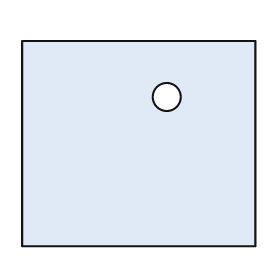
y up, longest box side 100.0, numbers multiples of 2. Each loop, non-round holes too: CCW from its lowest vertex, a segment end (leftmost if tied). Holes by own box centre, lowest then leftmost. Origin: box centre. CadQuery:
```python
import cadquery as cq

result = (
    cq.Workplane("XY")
    .moveTo(-50.0, -44.0)
    .lineTo(50.0, -44.0)
    .lineTo(50.0, 44.0)
    .lineTo(-50.0, 44.0)
    .close()
    .moveTo(12.0, 20.0)
    .circle(6.0)
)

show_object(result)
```